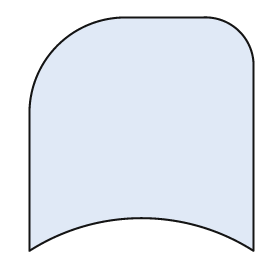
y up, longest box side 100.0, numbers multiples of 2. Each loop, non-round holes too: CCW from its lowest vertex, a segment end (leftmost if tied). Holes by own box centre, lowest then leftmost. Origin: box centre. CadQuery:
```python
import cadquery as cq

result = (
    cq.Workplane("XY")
    .moveTo(-48.0, -50.0)
    .threePointArc((0.0, -36.0), (48.0, -50.0))
    .lineTo(48.0, 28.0)
    .threePointArc((42.0, 44.0), (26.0, 50.0))
    .lineTo(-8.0, 50.0)
    .threePointArc((-36.0, 38.0), (-48.0, 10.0))
    .close()
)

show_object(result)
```